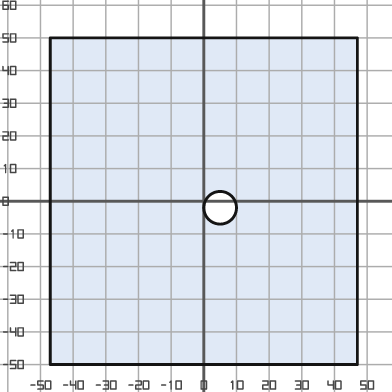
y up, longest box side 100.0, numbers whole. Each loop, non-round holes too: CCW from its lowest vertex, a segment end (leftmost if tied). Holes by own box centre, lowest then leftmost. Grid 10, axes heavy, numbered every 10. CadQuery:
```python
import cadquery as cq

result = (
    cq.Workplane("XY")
    .moveTo(-47.0, -50.0)
    .lineTo(47.0, -50.0)
    .lineTo(47.0, 50.0)
    .lineTo(-47.0, 50.0)
    .close()
    .moveTo(5.0, -2.0)
    .circle(5.0)
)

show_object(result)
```